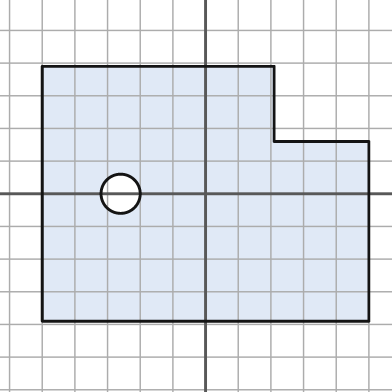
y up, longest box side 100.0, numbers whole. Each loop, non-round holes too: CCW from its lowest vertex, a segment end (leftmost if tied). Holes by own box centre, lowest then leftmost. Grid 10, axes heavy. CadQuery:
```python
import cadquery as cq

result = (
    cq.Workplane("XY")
    .moveTo(-50.0, -39.0)
    .lineTo(50.0, -39.0)
    .lineTo(50.0, 16.0)
    .lineTo(21.0, 16.0)
    .lineTo(21.0, 39.0)
    .lineTo(-50.0, 39.0)
    .close()
    .moveTo(-26.0, 0.0)
    .circle(6.0)
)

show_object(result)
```